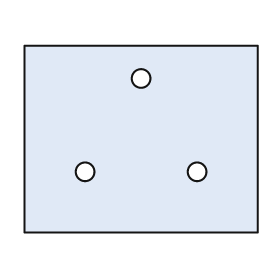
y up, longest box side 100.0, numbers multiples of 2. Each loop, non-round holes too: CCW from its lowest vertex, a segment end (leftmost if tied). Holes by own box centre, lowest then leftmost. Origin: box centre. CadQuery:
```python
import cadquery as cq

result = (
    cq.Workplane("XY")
    .moveTo(-50.0, -40.0)
    .lineTo(50.0, -40.0)
    .lineTo(50.0, 40.0)
    .lineTo(-50.0, 40.0)
    .close()
    .moveTo(-24.0, -14.0)
    .circle(4.0)
    .moveTo(24.0, -14.0)
    .circle(4.0)
    .moveTo(0.0, 26.0)
    .circle(4.0)
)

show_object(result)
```